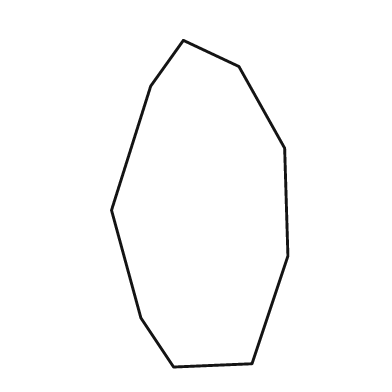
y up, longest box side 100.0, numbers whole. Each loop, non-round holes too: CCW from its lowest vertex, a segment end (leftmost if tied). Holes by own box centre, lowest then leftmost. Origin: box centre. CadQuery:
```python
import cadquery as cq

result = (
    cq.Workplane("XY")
    .moveTo(-8.0, -50.0)
    .lineTo(16.0, -49.0)
    .lineTo(27.0, -16.0)
    .lineTo(26.0, 17.0)
    .lineTo(12.0, 42.0)
    .lineTo(-5.0, 50.0)
    .lineTo(-15.0, 36.0)
    .lineTo(-27.0, -2.0)
    .lineTo(-18.0, -35.0)
    .close()
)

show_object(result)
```